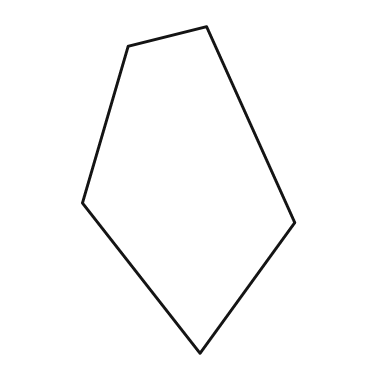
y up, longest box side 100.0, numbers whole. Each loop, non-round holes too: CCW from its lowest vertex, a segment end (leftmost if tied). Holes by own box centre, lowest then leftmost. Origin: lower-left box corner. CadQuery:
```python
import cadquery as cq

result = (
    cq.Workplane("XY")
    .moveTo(36.0, 0.0)
    .lineTo(65.0, 40.0)
    .lineTo(38.0, 100.0)
    .lineTo(14.0, 94.0)
    .lineTo(0.0, 46.0)
    .close()
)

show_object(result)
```